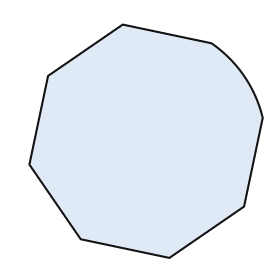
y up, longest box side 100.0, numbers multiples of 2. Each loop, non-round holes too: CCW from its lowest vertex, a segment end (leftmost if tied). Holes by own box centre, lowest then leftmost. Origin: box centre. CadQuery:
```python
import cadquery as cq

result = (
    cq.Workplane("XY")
    .moveTo(10.0, -50.0)
    .lineTo(42.0, -28.0)
    .lineTo(50.0, 10.0)
    .threePointArc((42.0, 28.0), (28.0, 42.0))
    .lineTo(-10.0, 50.0)
    .lineTo(-42.0, 28.0)
    .lineTo(-50.0, -10.0)
    .lineTo(-28.0, -42.0)
    .close()
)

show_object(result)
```